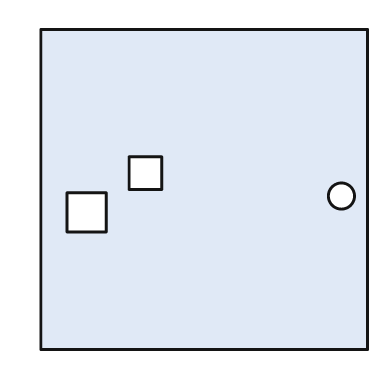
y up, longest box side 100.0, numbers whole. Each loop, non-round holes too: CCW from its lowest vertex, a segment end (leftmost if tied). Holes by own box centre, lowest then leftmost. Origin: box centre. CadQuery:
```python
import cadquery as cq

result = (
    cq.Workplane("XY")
    .moveTo(-50.0, -49.0)
    .lineTo(50.0, -49.0)
    .lineTo(50.0, 49.0)
    .lineTo(-50.0, 49.0)
    .close()
    .moveTo(-42.0, -13.0)
    .lineTo(-30.0, -13.0)
    .lineTo(-30.0, -1.0)
    .lineTo(-42.0, -1.0)
    .close()
    .moveTo(42.0, -2.0)
    .circle(4.0)
    .moveTo(-23.0, 0.0)
    .lineTo(-13.0, 0.0)
    .lineTo(-13.0, 10.0)
    .lineTo(-23.0, 10.0)
    .close()
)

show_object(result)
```